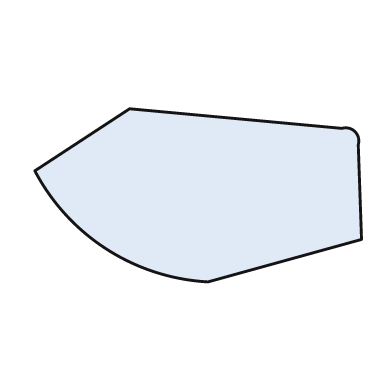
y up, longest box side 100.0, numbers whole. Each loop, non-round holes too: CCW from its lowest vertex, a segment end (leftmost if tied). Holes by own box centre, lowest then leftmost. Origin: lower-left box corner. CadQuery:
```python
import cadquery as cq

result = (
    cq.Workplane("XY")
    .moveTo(53.0, 0.0)
    .lineTo(100.0, 13.0)
    .lineTo(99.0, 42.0)
    .threePointArc((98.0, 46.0), (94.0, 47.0))
    .lineTo(29.0, 53.0)
    .lineTo(0.0, 34.0)
    .threePointArc((22.0, 10.0), (53.0, 0.0))
    .close()
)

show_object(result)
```